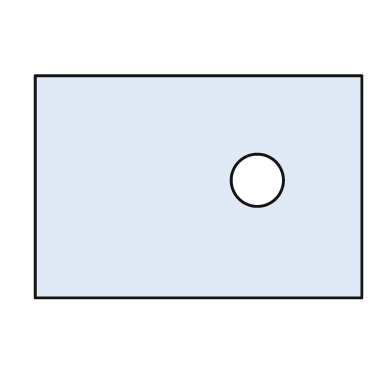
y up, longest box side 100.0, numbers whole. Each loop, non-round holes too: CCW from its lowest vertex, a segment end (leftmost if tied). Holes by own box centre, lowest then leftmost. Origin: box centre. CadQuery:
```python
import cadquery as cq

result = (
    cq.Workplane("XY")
    .moveTo(-50.0, -34.0)
    .lineTo(50.0, -34.0)
    .lineTo(50.0, 34.0)
    .lineTo(-50.0, 34.0)
    .close()
    .moveTo(18.0, 2.0)
    .circle(8.0)
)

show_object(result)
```